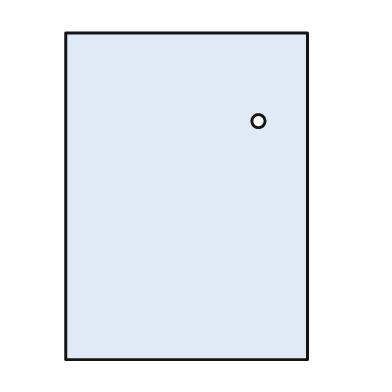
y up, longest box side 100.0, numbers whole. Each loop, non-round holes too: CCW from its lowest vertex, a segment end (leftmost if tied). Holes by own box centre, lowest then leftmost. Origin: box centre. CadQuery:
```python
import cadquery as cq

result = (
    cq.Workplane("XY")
    .moveTo(-37.0, -50.0)
    .lineTo(37.0, -50.0)
    .lineTo(37.0, 50.0)
    .lineTo(-37.0, 50.0)
    .close()
    .moveTo(22.0, 23.0)
    .circle(2.0)
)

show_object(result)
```